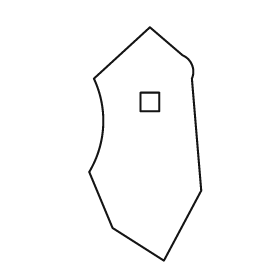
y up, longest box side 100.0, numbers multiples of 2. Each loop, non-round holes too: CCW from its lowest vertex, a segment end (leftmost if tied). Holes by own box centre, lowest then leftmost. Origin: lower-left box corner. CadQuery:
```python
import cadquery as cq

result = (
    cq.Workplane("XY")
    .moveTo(32.0, 0.0)
    .lineTo(48.0, 30.0)
    .lineTo(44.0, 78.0)
    .threePointArc((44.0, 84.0), (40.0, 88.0))
    .lineTo(26.0, 100.0)
    .lineTo(2.0, 78.0)
    .threePointArc((6.0, 58.0), (0.0, 38.0))
    .lineTo(10.0, 14.0)
    .close()
    .moveTo(22.0, 64.0)
    .lineTo(30.0, 64.0)
    .lineTo(30.0, 72.0)
    .lineTo(22.0, 72.0)
    .close()
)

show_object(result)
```